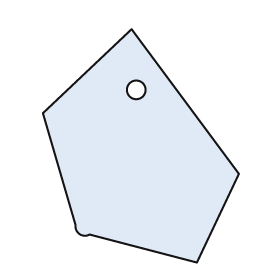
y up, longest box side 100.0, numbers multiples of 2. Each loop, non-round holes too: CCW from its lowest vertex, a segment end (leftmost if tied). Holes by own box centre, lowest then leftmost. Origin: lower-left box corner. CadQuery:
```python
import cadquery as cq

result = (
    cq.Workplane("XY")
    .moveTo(66.0, 0.0)
    .lineTo(84.0, 38.0)
    .lineTo(38.0, 100.0)
    .lineTo(0.0, 64.0)
    .lineTo(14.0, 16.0)
    .threePointArc((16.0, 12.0), (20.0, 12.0))
    .close()
    .moveTo(40.0, 74.0)
    .circle(4.0)
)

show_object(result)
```